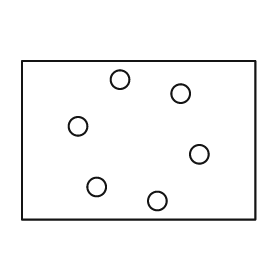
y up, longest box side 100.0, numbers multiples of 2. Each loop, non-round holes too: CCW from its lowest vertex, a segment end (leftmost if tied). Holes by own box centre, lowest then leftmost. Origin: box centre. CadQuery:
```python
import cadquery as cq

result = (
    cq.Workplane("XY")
    .moveTo(-50.0, -34.0)
    .lineTo(50.0, -34.0)
    .lineTo(50.0, 34.0)
    .lineTo(-50.0, 34.0)
    .close()
    .moveTo(8.0, -26.0)
    .circle(4.0)
    .moveTo(-18.0, -20.0)
    .circle(4.0)
    .moveTo(26.0, -6.0)
    .circle(4.0)
    .moveTo(-26.0, 6.0)
    .circle(4.0)
    .moveTo(18.0, 20.0)
    .circle(4.0)
    .moveTo(-8.0, 26.0)
    .circle(4.0)
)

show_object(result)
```